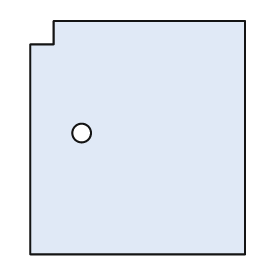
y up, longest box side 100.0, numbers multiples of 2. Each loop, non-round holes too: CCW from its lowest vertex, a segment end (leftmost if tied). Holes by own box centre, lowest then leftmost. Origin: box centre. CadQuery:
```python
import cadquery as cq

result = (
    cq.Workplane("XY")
    .moveTo(-46.0, -50.0)
    .lineTo(46.0, -50.0)
    .lineTo(46.0, 50.0)
    .lineTo(-36.0, 50.0)
    .lineTo(-36.0, 40.0)
    .lineTo(-46.0, 40.0)
    .close()
    .moveTo(-24.0, 2.0)
    .circle(4.0)
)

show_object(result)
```